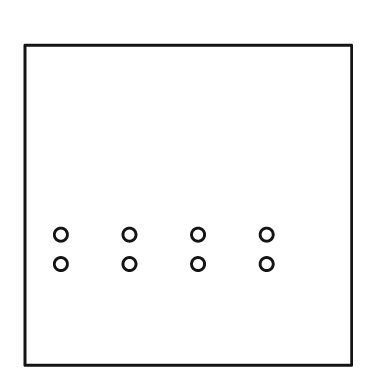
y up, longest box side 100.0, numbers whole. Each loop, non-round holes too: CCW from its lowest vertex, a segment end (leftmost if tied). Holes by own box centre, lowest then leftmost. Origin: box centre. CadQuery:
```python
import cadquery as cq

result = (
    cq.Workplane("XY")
    .moveTo(-50.0, -49.0)
    .lineTo(50.0, -49.0)
    .lineTo(50.0, 49.0)
    .lineTo(-50.0, 49.0)
    .close()
    .moveTo(-39.0, -18.0)
    .circle(2.0)
    .moveTo(-18.0, -18.0)
    .circle(2.0)
    .moveTo(3.0, -18.0)
    .circle(2.0)
    .moveTo(24.0, -18.0)
    .circle(2.0)
    .moveTo(-39.0, -9.0)
    .circle(2.0)
    .moveTo(-18.0, -9.0)
    .circle(2.0)
    .moveTo(3.0, -9.0)
    .circle(2.0)
    .moveTo(24.0, -9.0)
    .circle(2.0)
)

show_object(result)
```